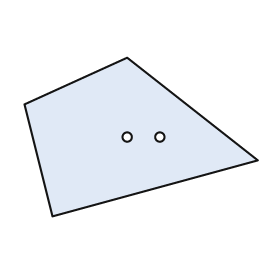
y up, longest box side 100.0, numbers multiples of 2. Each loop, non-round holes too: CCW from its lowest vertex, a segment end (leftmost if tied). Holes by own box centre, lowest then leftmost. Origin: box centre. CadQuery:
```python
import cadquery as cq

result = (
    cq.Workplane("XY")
    .moveTo(-38.0, -34.0)
    .lineTo(50.0, -10.0)
    .lineTo(-6.0, 34.0)
    .lineTo(-50.0, 14.0)
    .close()
    .moveTo(-6.0, 0.0)
    .circle(2.0)
    .moveTo(8.0, 0.0)
    .circle(2.0)
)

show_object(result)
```